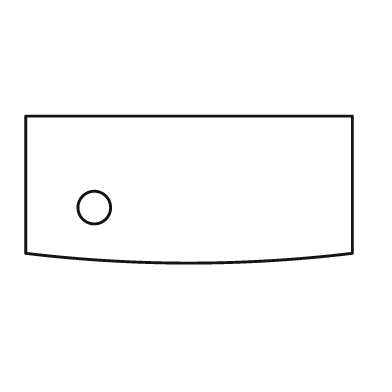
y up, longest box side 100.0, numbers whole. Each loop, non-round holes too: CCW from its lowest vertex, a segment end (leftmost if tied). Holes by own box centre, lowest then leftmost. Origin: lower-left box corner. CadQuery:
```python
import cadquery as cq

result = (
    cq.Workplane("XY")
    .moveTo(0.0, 3.0)
    .threePointArc((50.0, 0.0), (100.0, 3.0))
    .lineTo(100.0, 45.0)
    .lineTo(0.0, 45.0)
    .close()
    .moveTo(21.0, 17.0)
    .circle(5.0)
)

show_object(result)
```